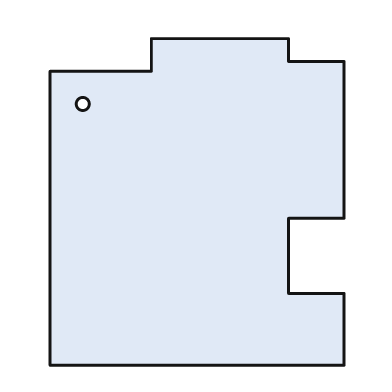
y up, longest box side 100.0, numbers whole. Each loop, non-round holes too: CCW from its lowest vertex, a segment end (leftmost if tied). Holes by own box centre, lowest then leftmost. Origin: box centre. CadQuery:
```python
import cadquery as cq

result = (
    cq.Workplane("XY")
    .moveTo(-45.0, -50.0)
    .lineTo(45.0, -50.0)
    .lineTo(45.0, -28.0)
    .lineTo(28.0, -28.0)
    .lineTo(28.0, -5.0)
    .lineTo(45.0, -5.0)
    .lineTo(45.0, 43.0)
    .lineTo(28.0, 43.0)
    .lineTo(28.0, 50.0)
    .lineTo(-14.0, 50.0)
    .lineTo(-14.0, 40.0)
    .lineTo(-45.0, 40.0)
    .close()
    .moveTo(-35.0, 30.0)
    .circle(2.0)
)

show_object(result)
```